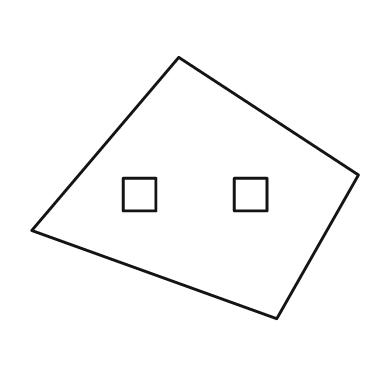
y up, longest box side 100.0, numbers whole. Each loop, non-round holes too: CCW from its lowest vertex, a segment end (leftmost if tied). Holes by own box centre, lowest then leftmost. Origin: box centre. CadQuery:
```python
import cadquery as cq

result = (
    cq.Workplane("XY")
    .moveTo(25.0, -40.0)
    .lineTo(50.0, 4.0)
    .lineTo(-5.0, 40.0)
    .lineTo(-50.0, -13.0)
    .close()
    .moveTo(-22.0, -7.0)
    .lineTo(-12.0, -7.0)
    .lineTo(-12.0, 3.0)
    .lineTo(-22.0, 3.0)
    .close()
    .moveTo(12.0, -7.0)
    .lineTo(22.0, -7.0)
    .lineTo(22.0, 3.0)
    .lineTo(12.0, 3.0)
    .close()
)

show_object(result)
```